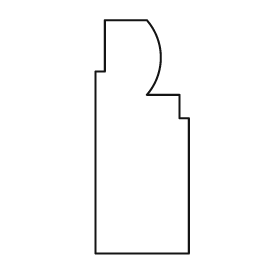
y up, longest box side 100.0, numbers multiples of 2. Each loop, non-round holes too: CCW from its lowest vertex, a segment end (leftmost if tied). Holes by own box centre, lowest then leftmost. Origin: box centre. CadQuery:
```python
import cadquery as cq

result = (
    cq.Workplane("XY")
    .moveTo(-20.0, -50.0)
    .lineTo(20.0, -50.0)
    .lineTo(20.0, 8.0)
    .lineTo(16.0, 8.0)
    .lineTo(16.0, 18.0)
    .lineTo(2.0, 18.0)
    .threePointArc((8.0, 34.0), (2.0, 50.0))
    .lineTo(-16.0, 50.0)
    .lineTo(-16.0, 28.0)
    .lineTo(-20.0, 28.0)
    .close()
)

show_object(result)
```